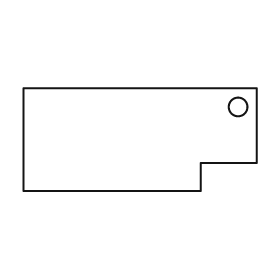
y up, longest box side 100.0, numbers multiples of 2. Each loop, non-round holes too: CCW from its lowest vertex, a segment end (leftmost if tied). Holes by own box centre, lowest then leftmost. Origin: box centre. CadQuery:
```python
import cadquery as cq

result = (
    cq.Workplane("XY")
    .moveTo(-50.0, -22.0)
    .lineTo(26.0, -22.0)
    .lineTo(26.0, -10.0)
    .lineTo(50.0, -10.0)
    .lineTo(50.0, 22.0)
    .lineTo(-50.0, 22.0)
    .close()
    .moveTo(42.0, 14.0)
    .circle(4.0)
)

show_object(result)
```